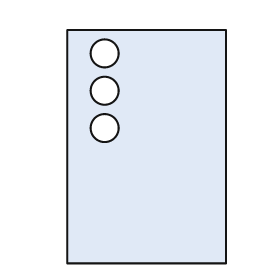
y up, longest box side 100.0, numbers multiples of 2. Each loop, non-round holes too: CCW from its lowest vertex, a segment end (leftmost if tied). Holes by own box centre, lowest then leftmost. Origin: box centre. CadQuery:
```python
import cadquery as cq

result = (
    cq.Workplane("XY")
    .moveTo(-34.0, -50.0)
    .lineTo(34.0, -50.0)
    .lineTo(34.0, 50.0)
    .lineTo(-34.0, 50.0)
    .close()
    .moveTo(-18.0, 8.0)
    .circle(6.0)
    .moveTo(-18.0, 24.0)
    .circle(6.0)
    .moveTo(-18.0, 40.0)
    .circle(6.0)
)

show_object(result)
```